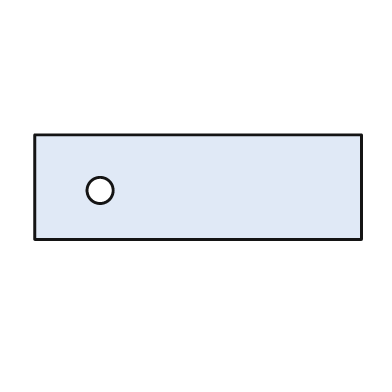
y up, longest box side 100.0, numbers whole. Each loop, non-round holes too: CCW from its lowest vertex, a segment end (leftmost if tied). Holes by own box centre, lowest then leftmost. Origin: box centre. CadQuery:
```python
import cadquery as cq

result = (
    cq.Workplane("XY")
    .moveTo(-50.0, -16.0)
    .lineTo(50.0, -16.0)
    .lineTo(50.0, 16.0)
    .lineTo(-50.0, 16.0)
    .close()
    .moveTo(-30.0, -1.0)
    .circle(4.0)
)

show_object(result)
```